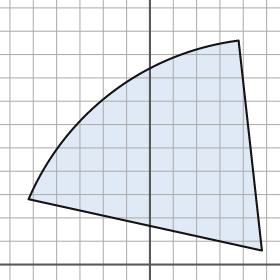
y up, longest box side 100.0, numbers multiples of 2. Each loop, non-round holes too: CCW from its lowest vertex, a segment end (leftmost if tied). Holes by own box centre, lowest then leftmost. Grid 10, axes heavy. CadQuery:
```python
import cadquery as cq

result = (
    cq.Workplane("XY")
    .moveTo(48.0, 6.0)
    .lineTo(38.0, 96.0)
    .threePointArc((-16.0, 74.0), (-52.0, 28.0))
    .close()
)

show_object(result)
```